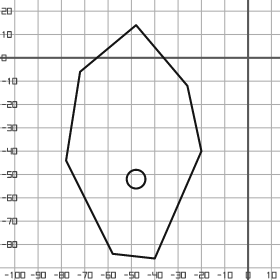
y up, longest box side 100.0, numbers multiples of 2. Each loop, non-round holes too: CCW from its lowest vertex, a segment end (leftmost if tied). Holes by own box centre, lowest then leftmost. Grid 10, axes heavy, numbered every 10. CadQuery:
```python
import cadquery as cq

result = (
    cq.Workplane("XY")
    .moveTo(-40.0, -86.0)
    .lineTo(-20.0, -40.0)
    .lineTo(-26.0, -12.0)
    .lineTo(-48.0, 14.0)
    .lineTo(-72.0, -6.0)
    .lineTo(-78.0, -44.0)
    .lineTo(-58.0, -84.0)
    .close()
    .moveTo(-48.0, -52.0)
    .circle(4.0)
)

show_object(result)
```